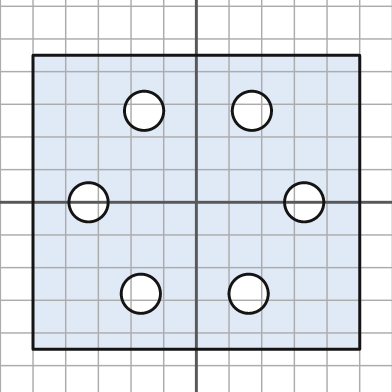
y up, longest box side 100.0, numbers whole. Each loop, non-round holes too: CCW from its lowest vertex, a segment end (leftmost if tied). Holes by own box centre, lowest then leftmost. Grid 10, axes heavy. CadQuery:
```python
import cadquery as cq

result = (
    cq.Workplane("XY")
    .moveTo(-50.0, -45.0)
    .lineTo(50.0, -45.0)
    .lineTo(50.0, 45.0)
    .lineTo(-50.0, 45.0)
    .close()
    .moveTo(-17.0, -28.0)
    .circle(6.0)
    .moveTo(16.0, -28.0)
    .circle(6.0)
    .moveTo(-33.0, 0.0)
    .circle(6.0)
    .moveTo(33.0, 0.0)
    .circle(6.0)
    .moveTo(-16.0, 28.0)
    .circle(6.0)
    .moveTo(17.0, 28.0)
    .circle(6.0)
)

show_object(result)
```